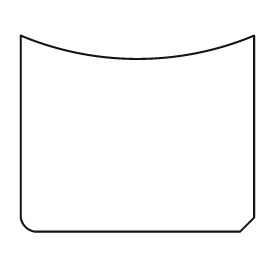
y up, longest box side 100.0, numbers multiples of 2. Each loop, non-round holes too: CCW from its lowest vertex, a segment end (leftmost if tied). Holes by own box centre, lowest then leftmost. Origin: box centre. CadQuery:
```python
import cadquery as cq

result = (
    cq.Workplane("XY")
    .moveTo(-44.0, -42.0)
    .lineTo(44.0, -42.0)
    .lineTo(50.0, -36.0)
    .lineTo(50.0, 42.0)
    .threePointArc((0.0, 32.0), (-50.0, 42.0))
    .lineTo(-50.0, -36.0)
    .threePointArc((-48.0, -40.0), (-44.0, -42.0))
    .close()
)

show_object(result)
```